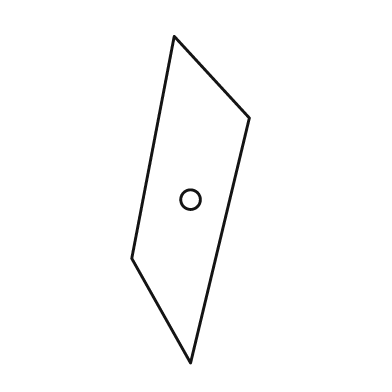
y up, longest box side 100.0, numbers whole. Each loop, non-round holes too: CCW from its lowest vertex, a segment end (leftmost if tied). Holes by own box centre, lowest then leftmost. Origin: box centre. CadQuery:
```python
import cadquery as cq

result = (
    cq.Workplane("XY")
    .moveTo(0.0, -50.0)
    .lineTo(18.0, 25.0)
    .lineTo(-5.0, 50.0)
    .lineTo(-18.0, -18.0)
    .close()
    .moveTo(0.0, 0.0)
    .circle(3.0)
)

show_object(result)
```